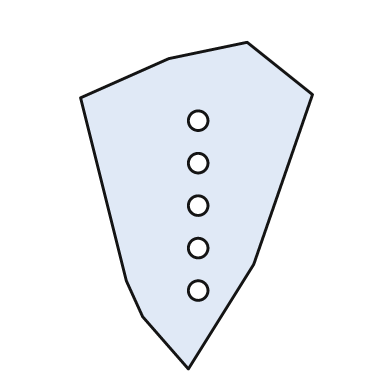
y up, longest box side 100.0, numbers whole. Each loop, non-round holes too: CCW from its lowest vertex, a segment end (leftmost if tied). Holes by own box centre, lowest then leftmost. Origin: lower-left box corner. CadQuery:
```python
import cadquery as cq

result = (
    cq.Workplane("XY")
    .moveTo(33.0, 0.0)
    .lineTo(53.0, 32.0)
    .lineTo(71.0, 84.0)
    .lineTo(51.0, 100.0)
    .lineTo(27.0, 95.0)
    .lineTo(0.0, 83.0)
    .lineTo(14.0, 27.0)
    .lineTo(19.0, 16.0)
    .close()
    .moveTo(36.0, 24.0)
    .circle(3.0)
    .moveTo(36.0, 37.0)
    .circle(3.0)
    .moveTo(36.0, 50.0)
    .circle(3.0)
    .moveTo(36.0, 63.0)
    .circle(3.0)
    .moveTo(36.0, 76.0)
    .circle(3.0)
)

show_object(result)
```